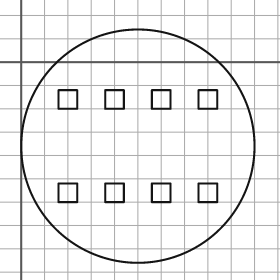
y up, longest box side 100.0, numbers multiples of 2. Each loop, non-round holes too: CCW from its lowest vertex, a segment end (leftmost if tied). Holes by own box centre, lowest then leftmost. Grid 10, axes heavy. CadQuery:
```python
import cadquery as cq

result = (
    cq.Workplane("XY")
    .moveTo(50.0, -36.0)
    .circle(50.0)
    .moveTo(16.0, -60.0)
    .lineTo(24.0, -60.0)
    .lineTo(24.0, -52.0)
    .lineTo(16.0, -52.0)
    .close()
    .moveTo(36.0, -60.0)
    .lineTo(44.0, -60.0)
    .lineTo(44.0, -52.0)
    .lineTo(36.0, -52.0)
    .close()
    .moveTo(56.0, -60.0)
    .lineTo(64.0, -60.0)
    .lineTo(64.0, -52.0)
    .lineTo(56.0, -52.0)
    .close()
    .moveTo(76.0, -60.0)
    .lineTo(84.0, -60.0)
    .lineTo(84.0, -52.0)
    .lineTo(76.0, -52.0)
    .close()
    .moveTo(16.0, -20.0)
    .lineTo(24.0, -20.0)
    .lineTo(24.0, -12.0)
    .lineTo(16.0, -12.0)
    .close()
    .moveTo(36.0, -20.0)
    .lineTo(44.0, -20.0)
    .lineTo(44.0, -12.0)
    .lineTo(36.0, -12.0)
    .close()
    .moveTo(56.0, -20.0)
    .lineTo(64.0, -20.0)
    .lineTo(64.0, -12.0)
    .lineTo(56.0, -12.0)
    .close()
    .moveTo(76.0, -20.0)
    .lineTo(84.0, -20.0)
    .lineTo(84.0, -12.0)
    .lineTo(76.0, -12.0)
    .close()
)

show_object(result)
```